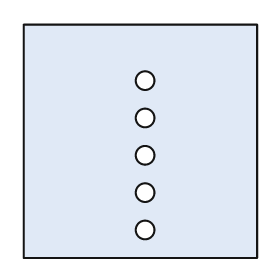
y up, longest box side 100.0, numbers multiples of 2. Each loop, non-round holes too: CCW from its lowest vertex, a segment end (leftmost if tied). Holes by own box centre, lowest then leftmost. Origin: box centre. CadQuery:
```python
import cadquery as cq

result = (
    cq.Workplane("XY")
    .moveTo(-50.0, -50.0)
    .lineTo(50.0, -50.0)
    .lineTo(50.0, 50.0)
    .lineTo(-50.0, 50.0)
    .close()
    .moveTo(2.0, -38.0)
    .circle(4.0)
    .moveTo(2.0, -22.0)
    .circle(4.0)
    .moveTo(2.0, -6.0)
    .circle(4.0)
    .moveTo(2.0, 10.0)
    .circle(4.0)
    .moveTo(2.0, 26.0)
    .circle(4.0)
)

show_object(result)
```